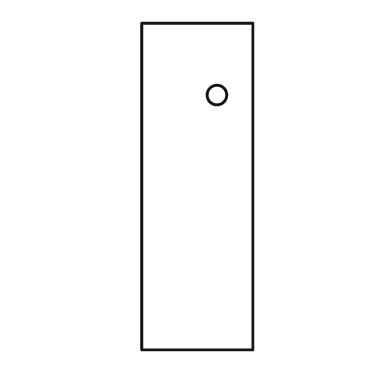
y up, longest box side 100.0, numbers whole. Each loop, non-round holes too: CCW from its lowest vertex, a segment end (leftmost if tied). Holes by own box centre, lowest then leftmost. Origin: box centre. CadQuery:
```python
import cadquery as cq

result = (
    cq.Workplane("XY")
    .moveTo(-17.0, -50.0)
    .lineTo(17.0, -50.0)
    .lineTo(17.0, 50.0)
    .lineTo(-17.0, 50.0)
    .close()
    .moveTo(6.0, 28.0)
    .circle(3.0)
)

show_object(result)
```